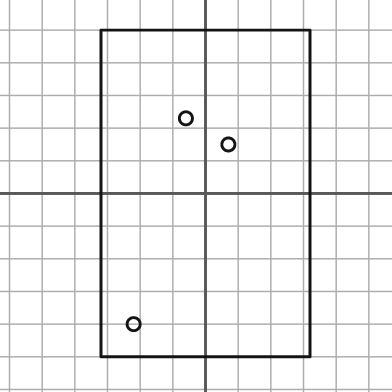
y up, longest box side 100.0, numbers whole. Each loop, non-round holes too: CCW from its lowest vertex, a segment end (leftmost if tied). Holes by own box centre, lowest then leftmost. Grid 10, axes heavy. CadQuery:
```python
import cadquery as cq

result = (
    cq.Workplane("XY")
    .moveTo(-32.0, -50.0)
    .lineTo(32.0, -50.0)
    .lineTo(32.0, 50.0)
    .lineTo(-32.0, 50.0)
    .close()
    .moveTo(-22.0, -40.0)
    .circle(2.0)
    .moveTo(7.0, 15.0)
    .circle(2.0)
    .moveTo(-6.0, 23.0)
    .circle(2.0)
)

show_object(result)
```